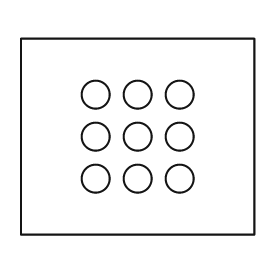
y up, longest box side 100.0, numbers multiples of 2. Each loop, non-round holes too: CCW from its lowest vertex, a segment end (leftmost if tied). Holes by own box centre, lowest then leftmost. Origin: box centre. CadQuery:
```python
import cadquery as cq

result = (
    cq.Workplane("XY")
    .moveTo(-50.0, -42.0)
    .lineTo(50.0, -42.0)
    .lineTo(50.0, 42.0)
    .lineTo(-50.0, 42.0)
    .close()
    .moveTo(-18.0, -18.0)
    .circle(6.0)
    .moveTo(0.0, -18.0)
    .circle(6.0)
    .moveTo(18.0, -18.0)
    .circle(6.0)
    .moveTo(-18.0, 0.0)
    .circle(6.0)
    .moveTo(0.0, 0.0)
    .circle(6.0)
    .moveTo(18.0, 0.0)
    .circle(6.0)
    .moveTo(-18.0, 18.0)
    .circle(6.0)
    .moveTo(0.0, 18.0)
    .circle(6.0)
    .moveTo(18.0, 18.0)
    .circle(6.0)
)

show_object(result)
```